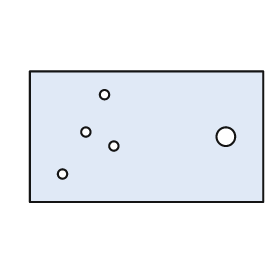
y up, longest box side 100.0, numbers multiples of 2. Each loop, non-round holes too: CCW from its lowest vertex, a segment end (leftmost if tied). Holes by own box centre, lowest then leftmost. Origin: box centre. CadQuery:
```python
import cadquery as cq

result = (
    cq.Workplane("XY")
    .moveTo(-50.0, -28.0)
    .lineTo(50.0, -28.0)
    .lineTo(50.0, 28.0)
    .lineTo(-50.0, 28.0)
    .close()
    .moveTo(-36.0, -16.0)
    .circle(2.0)
    .moveTo(-14.0, -4.0)
    .circle(2.0)
    .moveTo(34.0, 0.0)
    .circle(4.0)
    .moveTo(-26.0, 2.0)
    .circle(2.0)
    .moveTo(-18.0, 18.0)
    .circle(2.0)
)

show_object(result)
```